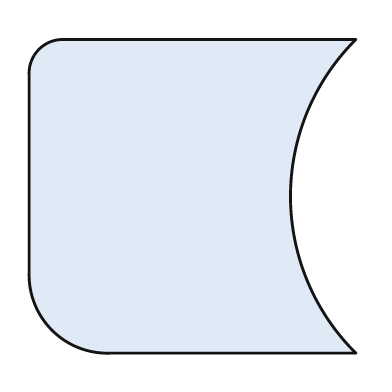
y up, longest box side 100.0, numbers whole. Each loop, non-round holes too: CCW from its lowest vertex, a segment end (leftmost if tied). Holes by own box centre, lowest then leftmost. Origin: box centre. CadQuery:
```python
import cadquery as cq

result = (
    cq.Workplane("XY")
    .moveTo(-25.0, -48.0)
    .lineTo(50.0, -48.0)
    .threePointArc((30.0, 0.0), (50.0, 48.0))
    .lineTo(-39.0, 48.0)
    .threePointArc((-47.0, 45.0), (-50.0, 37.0))
    .lineTo(-50.0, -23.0)
    .threePointArc((-43.0, -41.0), (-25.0, -48.0))
    .close()
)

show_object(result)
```